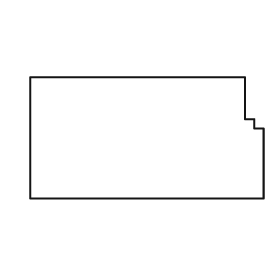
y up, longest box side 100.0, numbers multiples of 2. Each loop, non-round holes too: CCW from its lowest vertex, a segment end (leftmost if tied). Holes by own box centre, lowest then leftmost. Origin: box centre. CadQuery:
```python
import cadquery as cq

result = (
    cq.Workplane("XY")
    .moveTo(-50.0, -26.0)
    .lineTo(50.0, -26.0)
    .lineTo(50.0, 4.0)
    .lineTo(46.0, 4.0)
    .lineTo(46.0, 8.0)
    .lineTo(42.0, 8.0)
    .lineTo(42.0, 26.0)
    .lineTo(-50.0, 26.0)
    .close()
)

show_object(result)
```